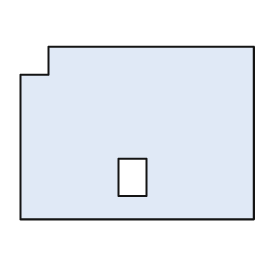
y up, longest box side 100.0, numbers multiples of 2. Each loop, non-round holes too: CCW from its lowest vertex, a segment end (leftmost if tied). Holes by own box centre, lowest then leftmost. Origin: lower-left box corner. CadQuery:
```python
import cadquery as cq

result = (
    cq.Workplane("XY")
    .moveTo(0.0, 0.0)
    .lineTo(100.0, 0.0)
    .lineTo(100.0, 74.0)
    .lineTo(12.0, 74.0)
    .lineTo(12.0, 62.0)
    .lineTo(0.0, 62.0)
    .close()
    .moveTo(42.0, 10.0)
    .lineTo(54.0, 10.0)
    .lineTo(54.0, 26.0)
    .lineTo(42.0, 26.0)
    .close()
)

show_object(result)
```